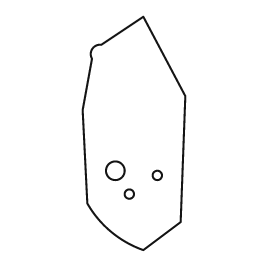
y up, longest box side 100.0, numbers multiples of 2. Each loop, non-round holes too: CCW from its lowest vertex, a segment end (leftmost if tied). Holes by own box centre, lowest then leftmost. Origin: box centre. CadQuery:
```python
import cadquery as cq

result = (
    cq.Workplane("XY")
    .moveTo(4.0, -50.0)
    .lineTo(20.0, -38.0)
    .lineTo(22.0, 16.0)
    .lineTo(4.0, 50.0)
    .lineTo(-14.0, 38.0)
    .threePointArc((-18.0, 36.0), (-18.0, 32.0))
    .lineTo(-22.0, 10.0)
    .lineTo(-20.0, -30.0)
    .threePointArc((-10.0, -42.0), (4.0, -50.0))
    .close()
    .moveTo(-2.0, -26.0)
    .circle(2.0)
    .moveTo(10.0, -18.0)
    .circle(2.0)
    .moveTo(-8.0, -16.0)
    .circle(4.0)
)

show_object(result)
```